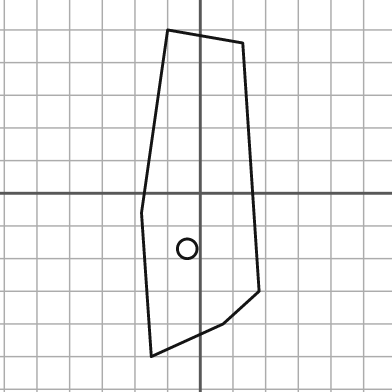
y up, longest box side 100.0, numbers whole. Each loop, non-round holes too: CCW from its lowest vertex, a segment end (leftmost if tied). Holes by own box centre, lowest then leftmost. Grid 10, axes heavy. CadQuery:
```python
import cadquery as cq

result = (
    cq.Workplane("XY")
    .moveTo(-15.0, -50.0)
    .lineTo(7.0, -40.0)
    .lineTo(18.0, -30.0)
    .lineTo(13.0, 46.0)
    .lineTo(-10.0, 50.0)
    .lineTo(-18.0, -6.0)
    .close()
    .moveTo(-4.0, -17.0)
    .circle(3.0)
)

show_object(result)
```